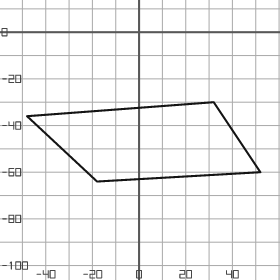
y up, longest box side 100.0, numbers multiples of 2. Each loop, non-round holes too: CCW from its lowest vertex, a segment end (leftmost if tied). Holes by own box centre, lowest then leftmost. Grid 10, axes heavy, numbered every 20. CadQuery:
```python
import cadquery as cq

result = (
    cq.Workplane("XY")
    .moveTo(-18.0, -64.0)
    .lineTo(52.0, -60.0)
    .lineTo(32.0, -30.0)
    .lineTo(-48.0, -36.0)
    .close()
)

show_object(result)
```